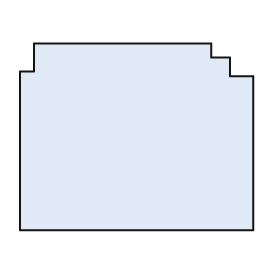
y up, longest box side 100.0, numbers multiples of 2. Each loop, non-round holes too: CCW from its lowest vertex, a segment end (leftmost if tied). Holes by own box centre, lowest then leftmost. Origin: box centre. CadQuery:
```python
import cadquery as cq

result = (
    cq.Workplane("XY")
    .moveTo(-50.0, -40.0)
    .lineTo(50.0, -40.0)
    .lineTo(50.0, 26.0)
    .lineTo(40.0, 26.0)
    .lineTo(40.0, 34.0)
    .lineTo(32.0, 34.0)
    .lineTo(32.0, 40.0)
    .lineTo(-44.0, 40.0)
    .lineTo(-44.0, 28.0)
    .lineTo(-50.0, 28.0)
    .close()
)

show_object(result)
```